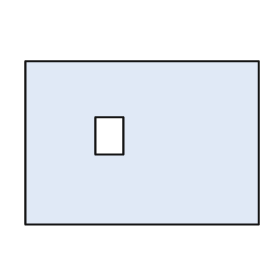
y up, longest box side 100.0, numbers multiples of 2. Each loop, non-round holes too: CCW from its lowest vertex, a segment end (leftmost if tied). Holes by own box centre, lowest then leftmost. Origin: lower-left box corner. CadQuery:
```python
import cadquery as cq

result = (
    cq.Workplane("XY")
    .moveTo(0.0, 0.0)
    .lineTo(100.0, 0.0)
    .lineTo(100.0, 70.0)
    .lineTo(0.0, 70.0)
    .close()
    .moveTo(30.0, 30.0)
    .lineTo(42.0, 30.0)
    .lineTo(42.0, 46.0)
    .lineTo(30.0, 46.0)
    .close()
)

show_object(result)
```